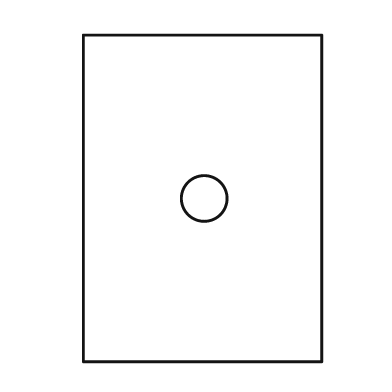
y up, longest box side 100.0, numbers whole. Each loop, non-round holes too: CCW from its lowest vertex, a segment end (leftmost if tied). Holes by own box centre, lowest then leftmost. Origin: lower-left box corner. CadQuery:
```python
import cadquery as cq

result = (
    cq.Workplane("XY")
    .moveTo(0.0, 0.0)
    .lineTo(73.0, 0.0)
    .lineTo(73.0, 100.0)
    .lineTo(0.0, 100.0)
    .close()
    .moveTo(37.0, 50.0)
    .circle(7.0)
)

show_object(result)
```